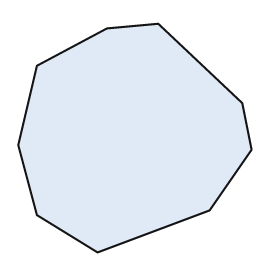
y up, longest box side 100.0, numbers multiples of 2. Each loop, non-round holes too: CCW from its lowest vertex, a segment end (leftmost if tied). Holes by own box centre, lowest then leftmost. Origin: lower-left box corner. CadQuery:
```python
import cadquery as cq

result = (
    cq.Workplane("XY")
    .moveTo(34.0, 0.0)
    .lineTo(82.0, 18.0)
    .lineTo(100.0, 44.0)
    .lineTo(96.0, 64.0)
    .lineTo(60.0, 98.0)
    .lineTo(38.0, 96.0)
    .lineTo(8.0, 80.0)
    .lineTo(0.0, 46.0)
    .lineTo(8.0, 16.0)
    .close()
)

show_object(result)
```